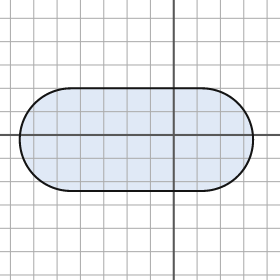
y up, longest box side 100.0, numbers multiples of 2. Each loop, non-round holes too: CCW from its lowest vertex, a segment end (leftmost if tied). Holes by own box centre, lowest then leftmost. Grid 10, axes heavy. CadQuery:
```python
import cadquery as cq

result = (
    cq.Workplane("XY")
    .moveTo(-44.0, -24.0)
    .lineTo(12.0, -24.0)
    .threePointArc((34.0, -2.0), (12.0, 20.0))
    .lineTo(-44.0, 20.0)
    .threePointArc((-66.0, -2.0), (-44.0, -24.0))
    .close()
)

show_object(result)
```